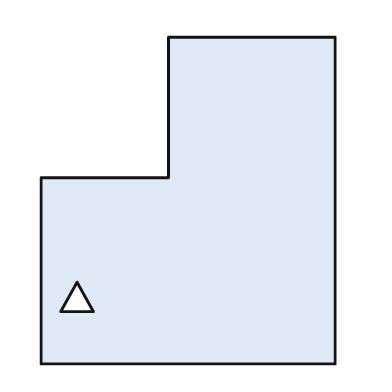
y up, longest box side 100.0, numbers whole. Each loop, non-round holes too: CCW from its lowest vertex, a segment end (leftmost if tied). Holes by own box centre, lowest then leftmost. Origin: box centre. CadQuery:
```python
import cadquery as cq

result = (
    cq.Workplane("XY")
    .moveTo(-45.0, -50.0)
    .lineTo(45.0, -50.0)
    .lineTo(45.0, 50.0)
    .lineTo(-6.0, 50.0)
    .lineTo(-6.0, 7.0)
    .lineTo(-45.0, 7.0)
    .close()
    .moveTo(-39.0, -34.0)
    .lineTo(-29.0, -34.0)
    .lineTo(-34.0, -25.0)
    .close()
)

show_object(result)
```